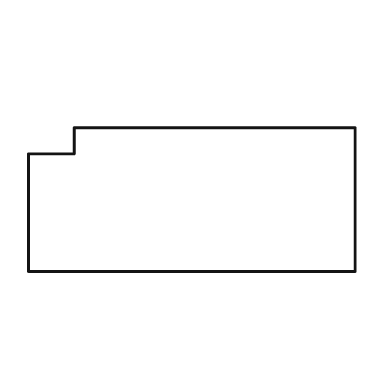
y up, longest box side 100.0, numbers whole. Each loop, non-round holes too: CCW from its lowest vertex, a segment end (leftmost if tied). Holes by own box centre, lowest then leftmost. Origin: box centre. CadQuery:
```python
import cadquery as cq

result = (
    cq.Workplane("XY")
    .moveTo(-50.0, -22.0)
    .lineTo(50.0, -22.0)
    .lineTo(50.0, 22.0)
    .lineTo(-36.0, 22.0)
    .lineTo(-36.0, 14.0)
    .lineTo(-50.0, 14.0)
    .close()
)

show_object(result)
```